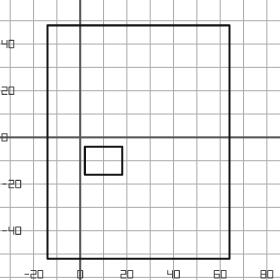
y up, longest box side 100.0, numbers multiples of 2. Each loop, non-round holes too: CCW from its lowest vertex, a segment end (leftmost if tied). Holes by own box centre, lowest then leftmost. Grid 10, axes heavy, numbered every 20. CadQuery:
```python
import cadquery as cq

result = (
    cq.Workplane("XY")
    .moveTo(-14.0, -52.0)
    .lineTo(64.0, -52.0)
    .lineTo(64.0, 48.0)
    .lineTo(-14.0, 48.0)
    .close()
    .moveTo(2.0, -16.0)
    .lineTo(18.0, -16.0)
    .lineTo(18.0, -4.0)
    .lineTo(2.0, -4.0)
    .close()
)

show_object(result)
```